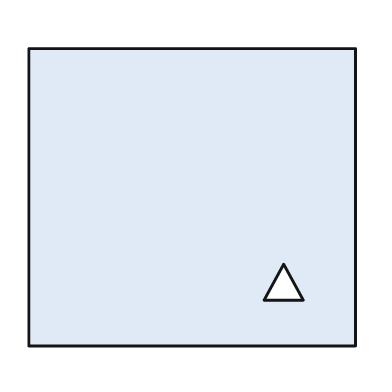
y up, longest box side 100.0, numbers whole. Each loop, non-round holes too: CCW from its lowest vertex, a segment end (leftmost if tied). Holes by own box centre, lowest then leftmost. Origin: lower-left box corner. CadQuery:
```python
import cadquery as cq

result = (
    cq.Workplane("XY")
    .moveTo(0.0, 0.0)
    .lineTo(100.0, 0.0)
    .lineTo(100.0, 91.0)
    .lineTo(0.0, 91.0)
    .close()
    .moveTo(72.0, 14.0)
    .lineTo(84.0, 14.0)
    .lineTo(78.0, 25.0)
    .close()
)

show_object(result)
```